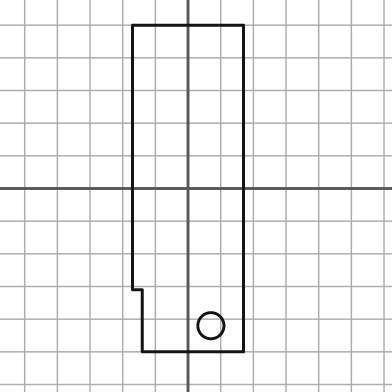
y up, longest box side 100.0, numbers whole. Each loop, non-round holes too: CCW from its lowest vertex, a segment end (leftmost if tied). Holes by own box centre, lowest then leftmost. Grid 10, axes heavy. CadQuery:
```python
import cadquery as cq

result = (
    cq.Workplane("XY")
    .moveTo(-14.0, -50.0)
    .lineTo(17.0, -50.0)
    .lineTo(17.0, 50.0)
    .lineTo(-17.0, 50.0)
    .lineTo(-17.0, -31.0)
    .lineTo(-14.0, -31.0)
    .close()
    .moveTo(7.0, -42.0)
    .circle(4.0)
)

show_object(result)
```